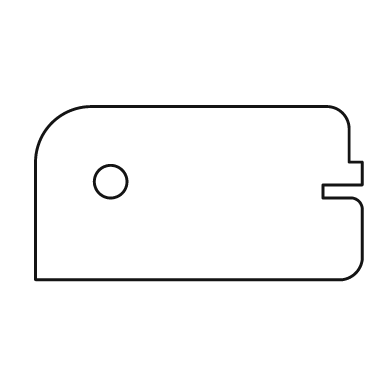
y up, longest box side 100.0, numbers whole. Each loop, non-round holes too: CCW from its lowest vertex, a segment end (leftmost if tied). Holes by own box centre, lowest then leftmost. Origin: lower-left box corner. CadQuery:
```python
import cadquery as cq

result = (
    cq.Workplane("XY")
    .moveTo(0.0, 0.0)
    .lineTo(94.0, 0.0)
    .threePointArc((98.0, 2.0), (100.0, 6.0))
    .lineTo(100.0, 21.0)
    .threePointArc((99.0, 24.0), (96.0, 25.0))
    .lineTo(88.0, 25.0)
    .lineTo(88.0, 29.0)
    .lineTo(100.0, 29.0)
    .lineTo(100.0, 36.0)
    .lineTo(96.0, 36.0)
    .lineTo(96.0, 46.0)
    .threePointArc((94.0, 51.0), (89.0, 53.0))
    .lineTo(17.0, 53.0)
    .threePointArc((5.0, 48.0), (0.0, 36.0))
    .close()
    .moveTo(23.0, 30.0)
    .circle(5.0)
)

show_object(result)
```